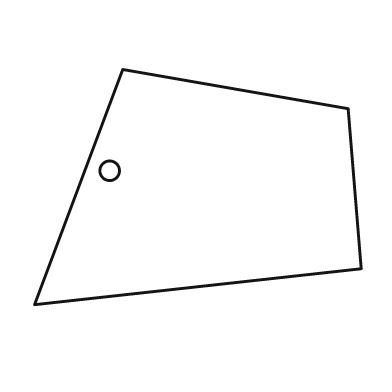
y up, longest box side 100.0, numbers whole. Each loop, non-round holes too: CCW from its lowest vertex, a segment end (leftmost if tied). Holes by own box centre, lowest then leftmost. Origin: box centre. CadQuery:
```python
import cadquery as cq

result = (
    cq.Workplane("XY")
    .moveTo(-50.0, -36.0)
    .lineTo(50.0, -25.0)
    .lineTo(46.0, 24.0)
    .lineTo(-23.0, 36.0)
    .close()
    .moveTo(-27.0, 5.0)
    .circle(3.0)
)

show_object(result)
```